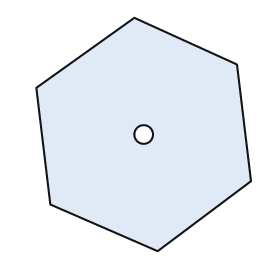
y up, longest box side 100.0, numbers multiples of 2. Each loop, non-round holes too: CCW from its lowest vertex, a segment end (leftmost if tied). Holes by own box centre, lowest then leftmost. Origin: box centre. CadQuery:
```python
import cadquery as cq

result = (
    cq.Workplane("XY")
    .moveTo(6.0, -50.0)
    .lineTo(46.0, -20.0)
    .lineTo(40.0, 30.0)
    .lineTo(-4.0, 50.0)
    .lineTo(-46.0, 20.0)
    .lineTo(-40.0, -30.0)
    .close()
    .moveTo(0.0, 0.0)
    .circle(4.0)
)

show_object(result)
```